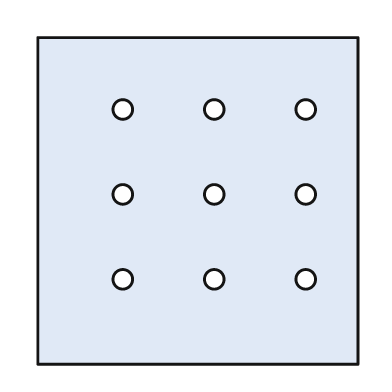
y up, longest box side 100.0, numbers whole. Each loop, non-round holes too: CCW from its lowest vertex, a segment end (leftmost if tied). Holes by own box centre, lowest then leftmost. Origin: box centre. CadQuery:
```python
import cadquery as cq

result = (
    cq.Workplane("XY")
    .moveTo(-49.0, -50.0)
    .lineTo(49.0, -50.0)
    .lineTo(49.0, 50.0)
    .lineTo(-49.0, 50.0)
    .close()
    .moveTo(-23.0, -24.0)
    .circle(3.0)
    .moveTo(5.0, -24.0)
    .circle(3.0)
    .moveTo(33.0, -24.0)
    .circle(3.0)
    .moveTo(-23.0, 2.0)
    .circle(3.0)
    .moveTo(5.0, 2.0)
    .circle(3.0)
    .moveTo(33.0, 2.0)
    .circle(3.0)
    .moveTo(-23.0, 28.0)
    .circle(3.0)
    .moveTo(5.0, 28.0)
    .circle(3.0)
    .moveTo(33.0, 28.0)
    .circle(3.0)
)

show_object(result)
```